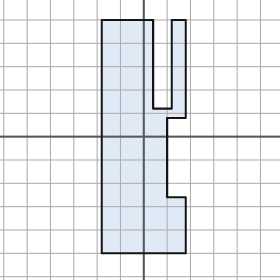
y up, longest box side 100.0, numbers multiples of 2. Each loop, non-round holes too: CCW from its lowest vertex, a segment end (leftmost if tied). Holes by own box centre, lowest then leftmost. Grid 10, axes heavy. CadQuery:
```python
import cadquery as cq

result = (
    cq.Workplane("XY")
    .moveTo(-18.0, -50.0)
    .lineTo(18.0, -50.0)
    .lineTo(18.0, -26.0)
    .lineTo(10.0, -26.0)
    .lineTo(10.0, 8.0)
    .lineTo(18.0, 8.0)
    .lineTo(18.0, 50.0)
    .lineTo(12.0, 50.0)
    .lineTo(12.0, 12.0)
    .lineTo(4.0, 12.0)
    .lineTo(4.0, 50.0)
    .lineTo(-18.0, 50.0)
    .close()
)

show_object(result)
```